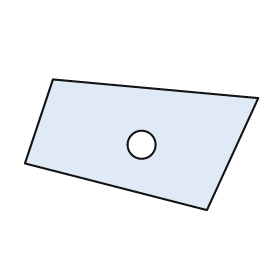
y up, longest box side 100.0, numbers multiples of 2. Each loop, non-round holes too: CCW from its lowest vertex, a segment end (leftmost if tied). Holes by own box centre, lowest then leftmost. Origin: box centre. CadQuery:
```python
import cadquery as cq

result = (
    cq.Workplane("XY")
    .moveTo(28.0, -28.0)
    .lineTo(50.0, 20.0)
    .lineTo(-38.0, 28.0)
    .lineTo(-50.0, -8.0)
    .close()
    .moveTo(0.0, 0.0)
    .circle(6.0)
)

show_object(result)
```